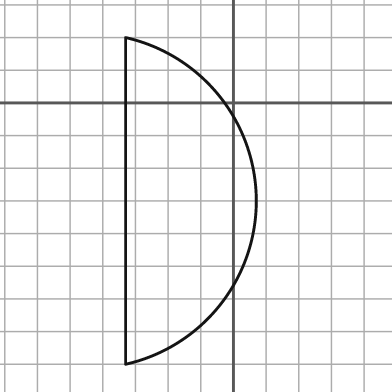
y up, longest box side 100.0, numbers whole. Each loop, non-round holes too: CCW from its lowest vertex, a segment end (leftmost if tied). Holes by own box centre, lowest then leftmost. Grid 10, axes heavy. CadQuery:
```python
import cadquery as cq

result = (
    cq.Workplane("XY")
    .moveTo(-33.0, -80.0)
    .threePointArc((7.0, -30.0), (-33.0, 20.0))
    .close()
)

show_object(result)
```